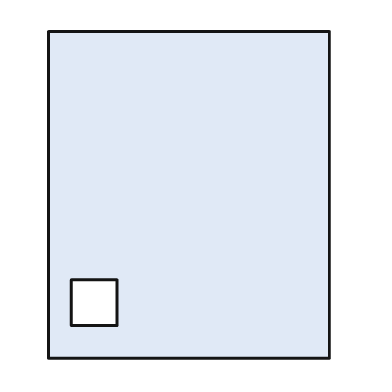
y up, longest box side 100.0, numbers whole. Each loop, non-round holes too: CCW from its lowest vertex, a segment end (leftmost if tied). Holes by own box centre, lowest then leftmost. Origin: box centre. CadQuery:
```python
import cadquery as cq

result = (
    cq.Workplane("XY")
    .moveTo(-43.0, -50.0)
    .lineTo(43.0, -50.0)
    .lineTo(43.0, 50.0)
    .lineTo(-43.0, 50.0)
    .close()
    .moveTo(-36.0, -40.0)
    .lineTo(-22.0, -40.0)
    .lineTo(-22.0, -26.0)
    .lineTo(-36.0, -26.0)
    .close()
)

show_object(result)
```